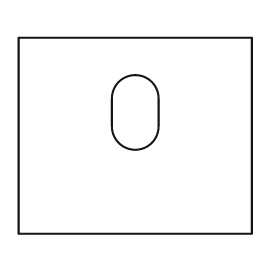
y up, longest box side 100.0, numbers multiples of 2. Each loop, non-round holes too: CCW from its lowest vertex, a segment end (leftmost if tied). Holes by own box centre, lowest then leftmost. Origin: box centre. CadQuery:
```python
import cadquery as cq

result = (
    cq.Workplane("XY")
    .moveTo(-50.0, -42.0)
    .lineTo(50.0, -42.0)
    .lineTo(50.0, 42.0)
    .lineTo(-50.0, 42.0)
    .close()
    .moveTo(-10.0, 4.0)
    .threePointArc((0.0, -6.0), (10.0, 4.0))
    .lineTo(10.0, 16.0)
    .threePointArc((0.0, 26.0), (-10.0, 16.0))
    .close()
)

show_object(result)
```